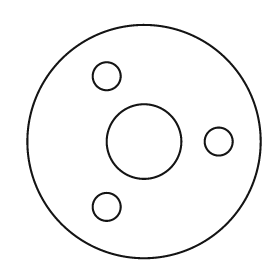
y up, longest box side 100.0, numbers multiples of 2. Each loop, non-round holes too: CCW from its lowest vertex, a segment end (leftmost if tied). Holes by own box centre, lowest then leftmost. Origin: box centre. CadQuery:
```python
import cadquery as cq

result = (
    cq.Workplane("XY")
    .moveTo(0.0, 0.0)
    .circle(50.0)
    .moveTo(-16.0, -28.0)
    .circle(6.0)
    .moveTo(0.0, 0.0)
    .circle(16.0)
    .moveTo(32.0, 0.0)
    .circle(6.0)
    .moveTo(-16.0, 28.0)
    .circle(6.0)
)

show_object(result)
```